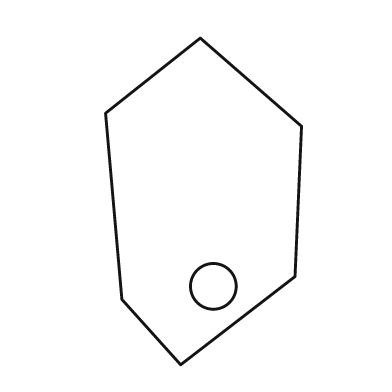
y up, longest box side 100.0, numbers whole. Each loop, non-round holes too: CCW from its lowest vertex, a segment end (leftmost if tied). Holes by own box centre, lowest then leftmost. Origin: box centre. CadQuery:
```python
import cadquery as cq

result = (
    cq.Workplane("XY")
    .moveTo(-7.0, -50.0)
    .lineTo(28.0, -23.0)
    .lineTo(30.0, 23.0)
    .lineTo(-1.0, 50.0)
    .lineTo(-30.0, 27.0)
    .lineTo(-25.0, -30.0)
    .close()
    .moveTo(3.0, -26.0)
    .circle(7.0)
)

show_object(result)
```